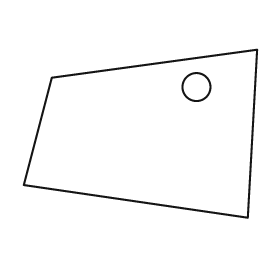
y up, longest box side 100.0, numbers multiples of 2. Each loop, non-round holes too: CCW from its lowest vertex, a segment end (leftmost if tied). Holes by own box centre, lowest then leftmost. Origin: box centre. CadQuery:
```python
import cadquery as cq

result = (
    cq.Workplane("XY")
    .moveTo(46.0, -36.0)
    .lineTo(50.0, 36.0)
    .lineTo(-38.0, 24.0)
    .lineTo(-50.0, -22.0)
    .close()
    .moveTo(24.0, 20.0)
    .circle(6.0)
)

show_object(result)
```